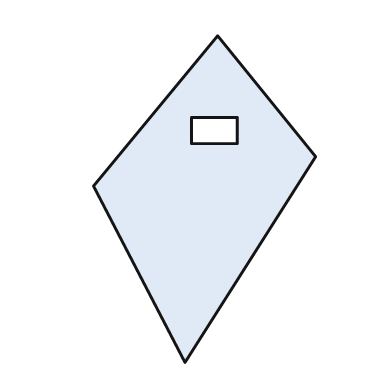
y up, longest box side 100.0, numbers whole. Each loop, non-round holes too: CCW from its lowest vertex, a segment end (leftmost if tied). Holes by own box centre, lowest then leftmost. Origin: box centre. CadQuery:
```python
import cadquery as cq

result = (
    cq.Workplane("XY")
    .moveTo(-6.0, -50.0)
    .lineTo(34.0, 13.0)
    .lineTo(4.0, 50.0)
    .lineTo(-34.0, 4.0)
    .close()
    .moveTo(-4.0, 17.0)
    .lineTo(10.0, 17.0)
    .lineTo(10.0, 25.0)
    .lineTo(-4.0, 25.0)
    .close()
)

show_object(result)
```